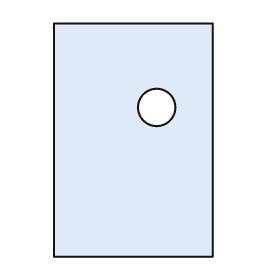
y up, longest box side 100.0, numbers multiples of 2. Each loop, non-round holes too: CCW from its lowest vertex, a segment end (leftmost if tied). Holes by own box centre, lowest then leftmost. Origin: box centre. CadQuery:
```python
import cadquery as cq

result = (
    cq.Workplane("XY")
    .moveTo(-34.0, -50.0)
    .lineTo(34.0, -50.0)
    .lineTo(34.0, 50.0)
    .lineTo(-34.0, 50.0)
    .close()
    .moveTo(10.0, 14.0)
    .circle(8.0)
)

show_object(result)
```